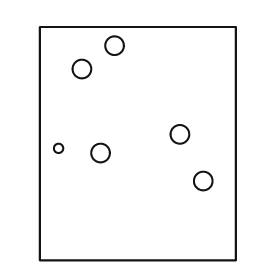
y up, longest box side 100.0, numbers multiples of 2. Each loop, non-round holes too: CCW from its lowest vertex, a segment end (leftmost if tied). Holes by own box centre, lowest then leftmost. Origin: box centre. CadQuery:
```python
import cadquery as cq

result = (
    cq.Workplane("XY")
    .moveTo(-42.0, -50.0)
    .lineTo(42.0, -50.0)
    .lineTo(42.0, 50.0)
    .lineTo(-42.0, 50.0)
    .close()
    .moveTo(28.0, -16.0)
    .circle(4.0)
    .moveTo(-16.0, -4.0)
    .circle(4.0)
    .moveTo(-34.0, -2.0)
    .circle(2.0)
    .moveTo(18.0, 4.0)
    .circle(4.0)
    .moveTo(-24.0, 32.0)
    .circle(4.0)
    .moveTo(-10.0, 42.0)
    .circle(4.0)
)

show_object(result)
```